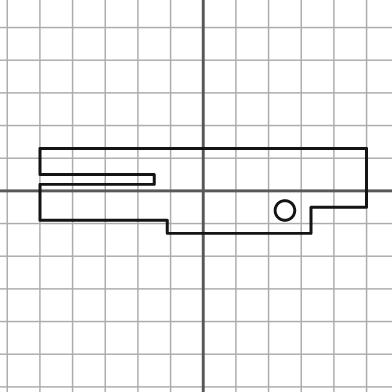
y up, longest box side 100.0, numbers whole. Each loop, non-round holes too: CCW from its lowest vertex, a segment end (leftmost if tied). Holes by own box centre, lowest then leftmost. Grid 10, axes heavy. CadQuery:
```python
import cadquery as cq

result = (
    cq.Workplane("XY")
    .moveTo(-11.0, -13.0)
    .lineTo(33.0, -13.0)
    .lineTo(33.0, -5.0)
    .lineTo(50.0, -5.0)
    .lineTo(50.0, 13.0)
    .lineTo(-50.0, 13.0)
    .lineTo(-50.0, 5.0)
    .lineTo(-15.0, 5.0)
    .lineTo(-15.0, 2.0)
    .lineTo(-50.0, 2.0)
    .lineTo(-50.0, -9.0)
    .lineTo(-11.0, -9.0)
    .close()
    .moveTo(25.0, -6.0)
    .circle(3.0)
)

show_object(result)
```